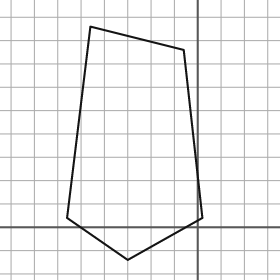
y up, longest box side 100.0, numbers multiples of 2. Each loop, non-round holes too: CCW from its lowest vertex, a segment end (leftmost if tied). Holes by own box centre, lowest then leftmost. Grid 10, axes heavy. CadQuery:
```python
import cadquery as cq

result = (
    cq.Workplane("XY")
    .moveTo(-30.0, -14.0)
    .lineTo(2.0, 4.0)
    .lineTo(-6.0, 76.0)
    .lineTo(-46.0, 86.0)
    .lineTo(-56.0, 4.0)
    .close()
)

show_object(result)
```